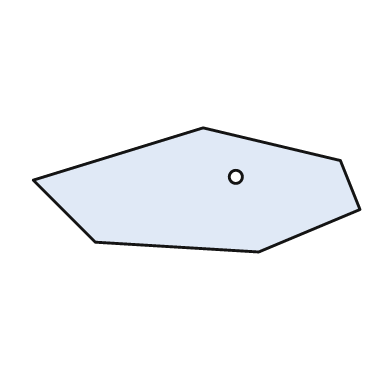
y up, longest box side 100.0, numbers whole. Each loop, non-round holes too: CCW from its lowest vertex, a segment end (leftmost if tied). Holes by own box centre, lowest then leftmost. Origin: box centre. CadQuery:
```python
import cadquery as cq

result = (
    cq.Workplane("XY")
    .moveTo(19.0, -19.0)
    .lineTo(50.0, -6.0)
    .lineTo(44.0, 9.0)
    .lineTo(2.0, 19.0)
    .lineTo(-50.0, 3.0)
    .lineTo(-31.0, -16.0)
    .close()
    .moveTo(12.0, 4.0)
    .circle(2.0)
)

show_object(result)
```